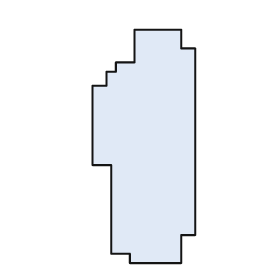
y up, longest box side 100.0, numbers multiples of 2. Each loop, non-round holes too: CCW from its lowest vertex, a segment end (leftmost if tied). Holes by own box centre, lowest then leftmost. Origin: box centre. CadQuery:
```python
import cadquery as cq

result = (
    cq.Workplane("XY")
    .moveTo(-6.0, -50.0)
    .lineTo(16.0, -50.0)
    .lineTo(16.0, -38.0)
    .lineTo(22.0, -38.0)
    .lineTo(22.0, 42.0)
    .lineTo(16.0, 42.0)
    .lineTo(16.0, 50.0)
    .lineTo(-4.0, 50.0)
    .lineTo(-4.0, 36.0)
    .lineTo(-12.0, 36.0)
    .lineTo(-12.0, 32.0)
    .lineTo(-16.0, 32.0)
    .lineTo(-16.0, 26.0)
    .lineTo(-22.0, 26.0)
    .lineTo(-22.0, -8.0)
    .lineTo(-14.0, -8.0)
    .lineTo(-14.0, -46.0)
    .lineTo(-6.0, -46.0)
    .close()
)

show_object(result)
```